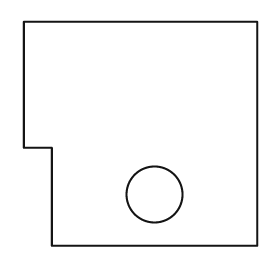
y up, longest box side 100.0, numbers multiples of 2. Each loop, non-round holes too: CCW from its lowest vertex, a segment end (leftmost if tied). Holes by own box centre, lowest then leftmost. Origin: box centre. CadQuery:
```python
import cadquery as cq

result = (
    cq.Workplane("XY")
    .moveTo(-38.0, -48.0)
    .lineTo(50.0, -48.0)
    .lineTo(50.0, 48.0)
    .lineTo(-50.0, 48.0)
    .lineTo(-50.0, -6.0)
    .lineTo(-38.0, -6.0)
    .close()
    .moveTo(6.0, -26.0)
    .circle(12.0)
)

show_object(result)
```